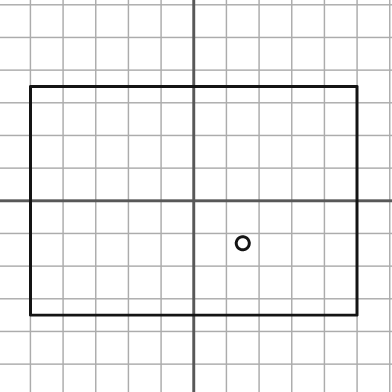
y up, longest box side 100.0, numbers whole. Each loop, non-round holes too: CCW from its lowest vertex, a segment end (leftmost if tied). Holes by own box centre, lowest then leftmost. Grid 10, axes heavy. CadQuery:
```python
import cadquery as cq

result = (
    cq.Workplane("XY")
    .moveTo(-50.0, -35.0)
    .lineTo(50.0, -35.0)
    .lineTo(50.0, 35.0)
    .lineTo(-50.0, 35.0)
    .close()
    .moveTo(15.0, -13.0)
    .circle(2.0)
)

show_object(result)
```